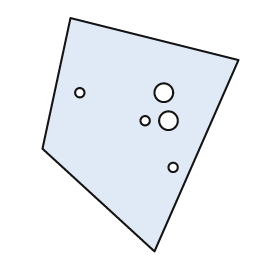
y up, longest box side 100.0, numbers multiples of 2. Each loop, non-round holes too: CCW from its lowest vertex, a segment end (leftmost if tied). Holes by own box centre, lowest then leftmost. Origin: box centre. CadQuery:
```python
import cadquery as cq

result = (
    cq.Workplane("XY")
    .moveTo(6.0, -50.0)
    .lineTo(42.0, 32.0)
    .lineTo(-30.0, 50.0)
    .lineTo(-42.0, -6.0)
    .close()
    .moveTo(14.0, -14.0)
    .circle(2.0)
    .moveTo(2.0, 6.0)
    .circle(2.0)
    .moveTo(12.0, 6.0)
    .circle(4.0)
    .moveTo(-26.0, 18.0)
    .circle(2.0)
    .moveTo(10.0, 18.0)
    .circle(4.0)
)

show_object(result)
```